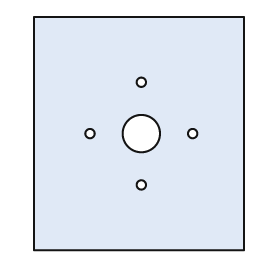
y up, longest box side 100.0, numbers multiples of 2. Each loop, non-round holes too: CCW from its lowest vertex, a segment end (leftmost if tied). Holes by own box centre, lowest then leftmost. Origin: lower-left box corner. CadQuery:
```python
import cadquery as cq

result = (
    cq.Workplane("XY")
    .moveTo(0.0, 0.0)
    .lineTo(90.0, 0.0)
    .lineTo(90.0, 100.0)
    .lineTo(0.0, 100.0)
    .close()
    .moveTo(46.0, 28.0)
    .circle(2.0)
    .moveTo(24.0, 50.0)
    .circle(2.0)
    .moveTo(46.0, 50.0)
    .circle(8.0)
    .moveTo(68.0, 50.0)
    .circle(2.0)
    .moveTo(46.0, 72.0)
    .circle(2.0)
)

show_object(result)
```